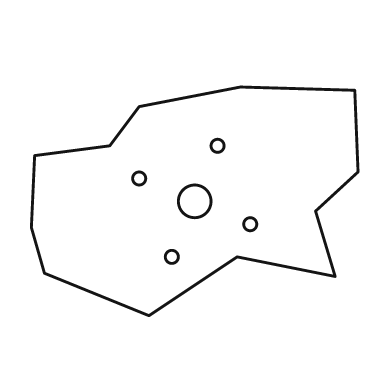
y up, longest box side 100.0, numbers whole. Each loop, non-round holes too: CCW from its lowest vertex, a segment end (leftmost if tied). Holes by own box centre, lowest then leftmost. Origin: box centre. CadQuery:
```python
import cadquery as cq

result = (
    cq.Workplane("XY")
    .moveTo(-14.0, -35.0)
    .lineTo(13.0, -17.0)
    .lineTo(43.0, -23.0)
    .lineTo(37.0, -3.0)
    .lineTo(50.0, 9.0)
    .lineTo(49.0, 34.0)
    .lineTo(14.0, 35.0)
    .lineTo(-17.0, 29.0)
    .lineTo(-26.0, 17.0)
    .lineTo(-49.0, 14.0)
    .lineTo(-50.0, -8.0)
    .lineTo(-46.0, -22.0)
    .close()
    .moveTo(-7.0, -17.0)
    .circle(2.0)
    .moveTo(17.0, -7.0)
    .circle(2.0)
    .moveTo(0.0, 0.0)
    .circle(5.0)
    .moveTo(-17.0, 7.0)
    .circle(2.0)
    .moveTo(7.0, 17.0)
    .circle(2.0)
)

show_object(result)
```